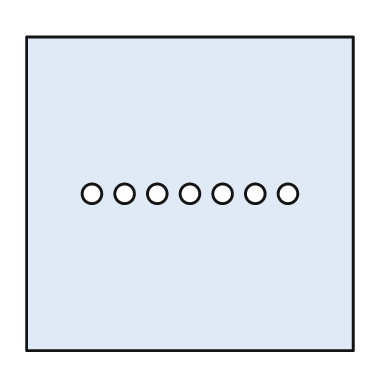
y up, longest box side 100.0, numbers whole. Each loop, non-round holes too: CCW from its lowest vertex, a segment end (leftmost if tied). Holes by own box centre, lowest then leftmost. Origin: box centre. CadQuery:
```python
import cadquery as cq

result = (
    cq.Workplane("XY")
    .moveTo(-50.0, -48.0)
    .lineTo(50.0, -48.0)
    .lineTo(50.0, 48.0)
    .lineTo(-50.0, 48.0)
    .close()
    .moveTo(-30.0, 0.0)
    .circle(3.0)
    .moveTo(-20.0, 0.0)
    .circle(3.0)
    .moveTo(-10.0, 0.0)
    .circle(3.0)
    .moveTo(0.0, 0.0)
    .circle(3.0)
    .moveTo(10.0, 0.0)
    .circle(3.0)
    .moveTo(20.0, 0.0)
    .circle(3.0)
    .moveTo(30.0, 0.0)
    .circle(3.0)
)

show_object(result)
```